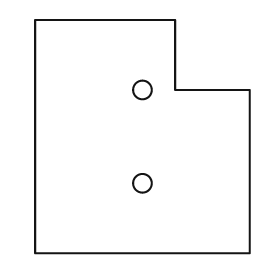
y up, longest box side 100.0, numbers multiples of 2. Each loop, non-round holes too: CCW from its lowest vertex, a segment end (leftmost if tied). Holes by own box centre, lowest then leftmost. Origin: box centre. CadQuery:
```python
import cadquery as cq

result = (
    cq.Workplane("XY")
    .moveTo(-46.0, -50.0)
    .lineTo(46.0, -50.0)
    .lineTo(46.0, 20.0)
    .lineTo(14.0, 20.0)
    .lineTo(14.0, 50.0)
    .lineTo(-46.0, 50.0)
    .close()
    .moveTo(0.0, -20.0)
    .circle(4.0)
    .moveTo(0.0, 20.0)
    .circle(4.0)
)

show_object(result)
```